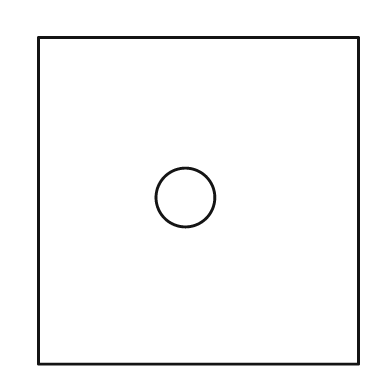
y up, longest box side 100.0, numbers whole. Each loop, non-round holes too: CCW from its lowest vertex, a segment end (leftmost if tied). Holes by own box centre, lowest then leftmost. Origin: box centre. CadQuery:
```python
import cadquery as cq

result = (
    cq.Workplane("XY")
    .moveTo(-49.0, -50.0)
    .lineTo(49.0, -50.0)
    .lineTo(49.0, 50.0)
    .lineTo(-49.0, 50.0)
    .close()
    .moveTo(-4.0, 1.0)
    .circle(9.0)
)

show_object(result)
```